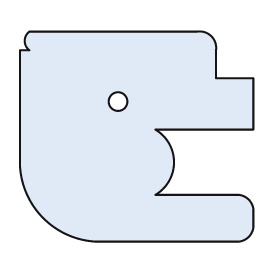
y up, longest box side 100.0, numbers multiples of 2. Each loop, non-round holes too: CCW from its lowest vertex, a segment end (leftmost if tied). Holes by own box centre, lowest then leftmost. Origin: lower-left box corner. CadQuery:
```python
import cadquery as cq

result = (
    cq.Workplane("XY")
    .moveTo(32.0, 0.0)
    .lineTo(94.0, 0.0)
    .threePointArc((98.0, 2.0), (100.0, 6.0))
    .lineTo(100.0, 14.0)
    .threePointArc((98.0, 18.0), (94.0, 20.0))
    .lineTo(58.0, 20.0)
    .threePointArc((66.0, 34.0), (58.0, 48.0))
    .lineTo(100.0, 48.0)
    .lineTo(100.0, 70.0)
    .lineTo(84.0, 70.0)
    .lineTo(84.0, 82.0)
    .threePointArc((82.0, 88.0), (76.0, 90.0))
    .lineTo(4.0, 90.0)
    .threePointArc((2.0, 86.0), (4.0, 82.0))
    .lineTo(0.0, 82.0)
    .lineTo(0.0, 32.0)
    .threePointArc((10.0, 10.0), (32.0, 0.0))
    .close()
    .moveTo(42.0, 60.0)
    .circle(4.0)
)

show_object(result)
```